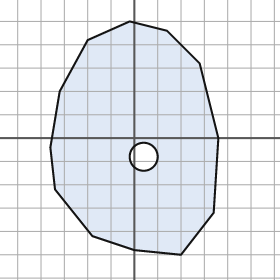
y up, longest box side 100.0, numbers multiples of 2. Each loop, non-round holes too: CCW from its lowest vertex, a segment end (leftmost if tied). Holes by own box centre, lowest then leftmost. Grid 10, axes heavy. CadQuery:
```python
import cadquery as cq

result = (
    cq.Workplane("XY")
    .moveTo(20.0, -50.0)
    .lineTo(34.0, -32.0)
    .lineTo(36.0, 0.0)
    .lineTo(28.0, 32.0)
    .lineTo(14.0, 46.0)
    .lineTo(-2.0, 50.0)
    .lineTo(-20.0, 42.0)
    .lineTo(-32.0, 20.0)
    .lineTo(-36.0, -4.0)
    .lineTo(-34.0, -22.0)
    .lineTo(-18.0, -42.0)
    .lineTo(0.0, -48.0)
    .close()
    .moveTo(4.0, -8.0)
    .circle(6.0)
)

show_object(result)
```